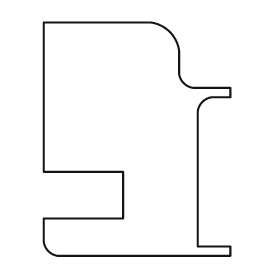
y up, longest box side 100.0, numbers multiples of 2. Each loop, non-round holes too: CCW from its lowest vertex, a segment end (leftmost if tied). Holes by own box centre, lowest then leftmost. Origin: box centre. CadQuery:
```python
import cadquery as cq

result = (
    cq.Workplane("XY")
    .moveTo(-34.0, -50.0)
    .lineTo(40.0, -50.0)
    .lineTo(40.0, -46.0)
    .lineTo(26.0, -46.0)
    .lineTo(26.0, 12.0)
    .threePointArc((28.0, 16.0), (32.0, 18.0))
    .lineTo(40.0, 18.0)
    .lineTo(40.0, 22.0)
    .lineTo(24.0, 22.0)
    .threePointArc((20.0, 24.0), (18.0, 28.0))
    .lineTo(18.0, 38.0)
    .threePointArc((14.0, 46.0), (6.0, 50.0))
    .lineTo(-40.0, 50.0)
    .lineTo(-40.0, -14.0)
    .lineTo(-6.0, -14.0)
    .lineTo(-6.0, -34.0)
    .lineTo(-40.0, -34.0)
    .lineTo(-40.0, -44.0)
    .threePointArc((-38.0, -48.0), (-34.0, -50.0))
    .close()
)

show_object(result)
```